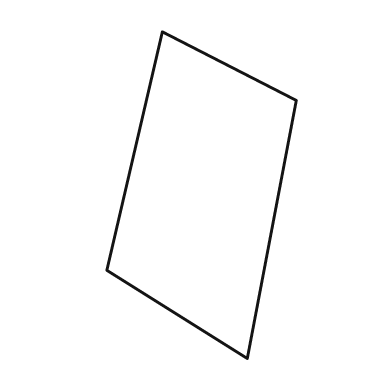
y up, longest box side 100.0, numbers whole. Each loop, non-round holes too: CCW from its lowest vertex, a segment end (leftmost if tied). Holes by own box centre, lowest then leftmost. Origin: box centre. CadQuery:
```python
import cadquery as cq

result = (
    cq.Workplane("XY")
    .moveTo(14.0, -50.0)
    .lineTo(29.0, 29.0)
    .lineTo(-12.0, 50.0)
    .lineTo(-29.0, -23.0)
    .close()
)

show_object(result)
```